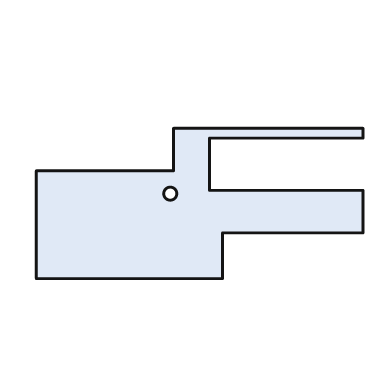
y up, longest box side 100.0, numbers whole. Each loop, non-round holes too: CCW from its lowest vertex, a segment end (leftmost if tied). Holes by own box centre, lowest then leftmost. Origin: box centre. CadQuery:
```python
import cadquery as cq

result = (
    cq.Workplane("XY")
    .moveTo(-50.0, -23.0)
    .lineTo(7.0, -23.0)
    .lineTo(7.0, -9.0)
    .lineTo(50.0, -9.0)
    .lineTo(50.0, 4.0)
    .lineTo(3.0, 4.0)
    .lineTo(3.0, 20.0)
    .lineTo(50.0, 20.0)
    .lineTo(50.0, 23.0)
    .lineTo(-8.0, 23.0)
    .lineTo(-8.0, 10.0)
    .lineTo(-50.0, 10.0)
    .close()
    .moveTo(-9.0, 3.0)
    .circle(2.0)
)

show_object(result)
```